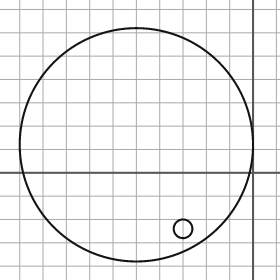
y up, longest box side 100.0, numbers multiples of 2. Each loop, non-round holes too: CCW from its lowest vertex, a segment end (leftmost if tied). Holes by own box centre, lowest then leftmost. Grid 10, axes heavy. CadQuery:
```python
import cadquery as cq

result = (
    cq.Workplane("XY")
    .moveTo(-50.0, 12.0)
    .circle(50.0)
    .moveTo(-30.0, -24.0)
    .circle(4.0)
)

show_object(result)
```